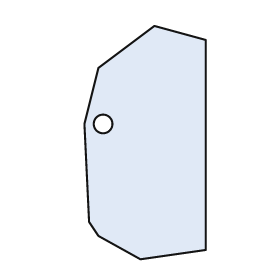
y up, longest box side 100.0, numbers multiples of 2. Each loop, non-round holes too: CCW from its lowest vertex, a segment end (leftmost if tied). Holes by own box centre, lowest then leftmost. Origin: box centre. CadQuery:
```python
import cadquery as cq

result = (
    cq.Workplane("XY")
    .moveTo(-2.0, -50.0)
    .lineTo(26.0, -46.0)
    .lineTo(26.0, 44.0)
    .lineTo(4.0, 50.0)
    .lineTo(-20.0, 32.0)
    .lineTo(-26.0, 8.0)
    .lineTo(-24.0, -34.0)
    .lineTo(-20.0, -40.0)
    .close()
    .moveTo(-18.0, 8.0)
    .circle(4.0)
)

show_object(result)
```